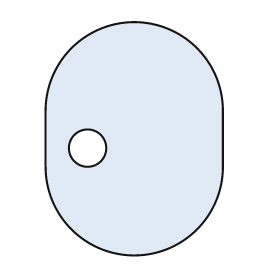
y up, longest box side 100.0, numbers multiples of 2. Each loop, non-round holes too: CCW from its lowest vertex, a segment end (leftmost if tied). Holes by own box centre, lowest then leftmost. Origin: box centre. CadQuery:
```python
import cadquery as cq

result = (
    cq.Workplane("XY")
    .moveTo(-38.0, -12.0)
    .threePointArc((0.0, -50.0), (38.0, -12.0))
    .lineTo(38.0, 12.0)
    .threePointArc((0.0, 50.0), (-38.0, 12.0))
    .close()
    .moveTo(-20.0, -4.0)
    .circle(8.0)
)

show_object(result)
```